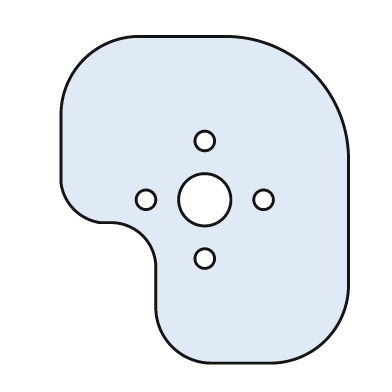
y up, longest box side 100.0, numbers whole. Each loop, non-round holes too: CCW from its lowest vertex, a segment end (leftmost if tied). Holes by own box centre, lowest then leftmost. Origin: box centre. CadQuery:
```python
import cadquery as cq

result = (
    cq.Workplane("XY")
    .moveTo(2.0, -50.0)
    .lineTo(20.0, -50.0)
    .threePointArc((37.0, -43.0), (44.0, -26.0))
    .lineTo(44.0, 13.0)
    .threePointArc((33.0, 39.0), (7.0, 50.0))
    .lineTo(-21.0, 50.0)
    .threePointArc((-37.0, 43.0), (-44.0, 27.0))
    .lineTo(-44.0, 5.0)
    .threePointArc((-40.0, -3.0), (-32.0, -7.0))
    .lineTo(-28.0, -7.0)
    .threePointArc((-19.0, -11.0), (-15.0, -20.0))
    .lineTo(-15.0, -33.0)
    .threePointArc((-10.0, -45.0), (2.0, -50.0))
    .close()
    .moveTo(0.0, -18.0)
    .circle(3.0)
    .moveTo(-18.0, 0.0)
    .circle(3.0)
    .moveTo(0.0, 0.0)
    .circle(8.0)
    .moveTo(18.0, 0.0)
    .circle(3.0)
    .moveTo(0.0, 18.0)
    .circle(3.0)
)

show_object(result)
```